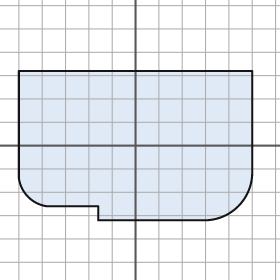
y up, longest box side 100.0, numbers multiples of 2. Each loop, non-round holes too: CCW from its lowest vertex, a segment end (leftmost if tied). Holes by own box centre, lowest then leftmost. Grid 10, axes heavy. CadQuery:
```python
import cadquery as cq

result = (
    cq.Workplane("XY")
    .moveTo(-16.0, -32.0)
    .lineTo(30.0, -32.0)
    .threePointArc((44.0, -26.0), (50.0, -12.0))
    .lineTo(50.0, 32.0)
    .lineTo(-50.0, 32.0)
    .lineTo(-50.0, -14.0)
    .threePointArc((-46.0, -22.0), (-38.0, -26.0))
    .lineTo(-16.0, -26.0)
    .close()
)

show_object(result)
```